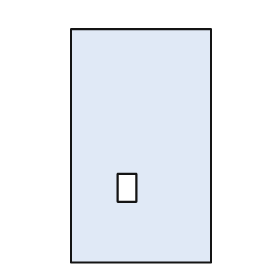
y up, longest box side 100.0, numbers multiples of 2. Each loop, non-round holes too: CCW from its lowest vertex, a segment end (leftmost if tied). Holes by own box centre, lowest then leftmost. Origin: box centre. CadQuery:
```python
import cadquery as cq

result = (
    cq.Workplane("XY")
    .moveTo(-30.0, -50.0)
    .lineTo(30.0, -50.0)
    .lineTo(30.0, 50.0)
    .lineTo(-30.0, 50.0)
    .close()
    .moveTo(-10.0, -24.0)
    .lineTo(-2.0, -24.0)
    .lineTo(-2.0, -12.0)
    .lineTo(-10.0, -12.0)
    .close()
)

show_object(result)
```